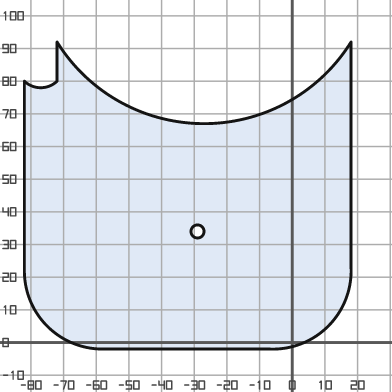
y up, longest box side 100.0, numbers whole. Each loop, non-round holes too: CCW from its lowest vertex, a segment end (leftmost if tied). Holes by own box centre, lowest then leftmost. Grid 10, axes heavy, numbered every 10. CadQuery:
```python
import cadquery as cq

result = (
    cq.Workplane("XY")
    .moveTo(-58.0, -2.0)
    .lineTo(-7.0, -2.0)
    .threePointArc((11.0, 5.0), (18.0, 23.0))
    .lineTo(18.0, 92.0)
    .threePointArc((-27.0, 67.0), (-72.0, 92.0))
    .lineTo(-72.0, 80.0)
    .threePointArc((-77.0, 78.0), (-82.0, 80.0))
    .lineTo(-82.0, 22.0)
    .threePointArc((-75.0, 5.0), (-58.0, -2.0))
    .close()
    .moveTo(-29.0, 34.0)
    .circle(2.0)
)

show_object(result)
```